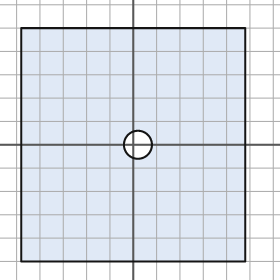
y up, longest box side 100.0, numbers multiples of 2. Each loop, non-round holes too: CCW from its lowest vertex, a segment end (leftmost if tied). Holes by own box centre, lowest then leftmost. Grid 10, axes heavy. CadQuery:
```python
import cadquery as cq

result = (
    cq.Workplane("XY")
    .moveTo(-48.0, -50.0)
    .lineTo(48.0, -50.0)
    .lineTo(48.0, 50.0)
    .lineTo(-48.0, 50.0)
    .close()
    .moveTo(2.0, 0.0)
    .circle(6.0)
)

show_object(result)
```